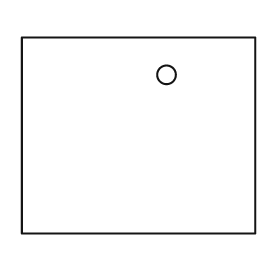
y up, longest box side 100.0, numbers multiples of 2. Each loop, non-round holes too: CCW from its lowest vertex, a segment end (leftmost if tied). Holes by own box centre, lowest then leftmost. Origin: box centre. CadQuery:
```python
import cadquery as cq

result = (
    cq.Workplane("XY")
    .moveTo(-50.0, -42.0)
    .lineTo(50.0, -42.0)
    .lineTo(50.0, 42.0)
    .lineTo(-50.0, 42.0)
    .close()
    .moveTo(12.0, 26.0)
    .circle(4.0)
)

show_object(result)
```